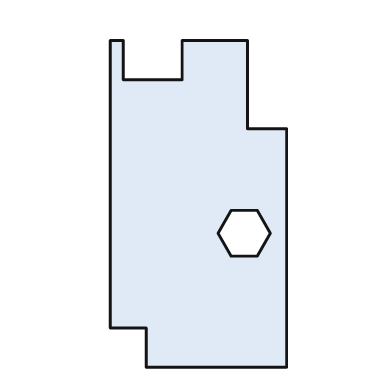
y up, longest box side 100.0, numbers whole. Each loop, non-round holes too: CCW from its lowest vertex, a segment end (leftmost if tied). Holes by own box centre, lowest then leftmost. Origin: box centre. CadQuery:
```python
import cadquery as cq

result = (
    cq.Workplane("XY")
    .moveTo(-16.0, -50.0)
    .lineTo(27.0, -50.0)
    .lineTo(27.0, 23.0)
    .lineTo(15.0, 23.0)
    .lineTo(15.0, 50.0)
    .lineTo(-5.0, 50.0)
    .lineTo(-5.0, 38.0)
    .lineTo(-23.0, 38.0)
    .lineTo(-23.0, 50.0)
    .lineTo(-27.0, 50.0)
    .lineTo(-27.0, -38.0)
    .lineTo(-16.0, -38.0)
    .close()
    .moveTo(10.0, -16.0)
    .lineTo(18.0, -16.0)
    .lineTo(22.0, -9.0)
    .lineTo(18.0, -2.0)
    .lineTo(10.0, -2.0)
    .lineTo(6.0, -9.0)
    .close()
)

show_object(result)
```